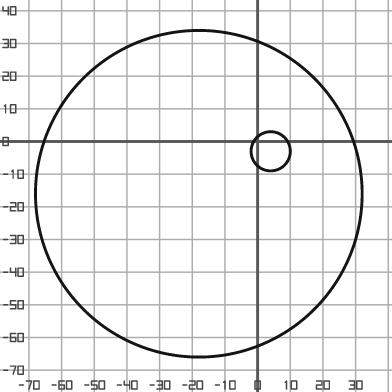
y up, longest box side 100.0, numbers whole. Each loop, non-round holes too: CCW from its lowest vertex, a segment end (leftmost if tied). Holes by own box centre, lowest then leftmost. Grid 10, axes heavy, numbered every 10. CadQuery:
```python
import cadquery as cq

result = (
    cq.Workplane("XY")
    .moveTo(-18.0, -16.0)
    .circle(50.0)
    .moveTo(4.0, -3.0)
    .circle(6.0)
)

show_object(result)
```